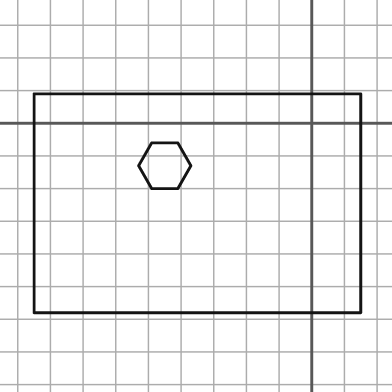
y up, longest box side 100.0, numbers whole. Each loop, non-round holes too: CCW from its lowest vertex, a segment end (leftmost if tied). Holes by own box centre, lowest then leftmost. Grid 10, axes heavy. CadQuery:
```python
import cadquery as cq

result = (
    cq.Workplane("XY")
    .moveTo(-85.0, -58.0)
    .lineTo(15.0, -58.0)
    .lineTo(15.0, 9.0)
    .lineTo(-85.0, 9.0)
    .close()
    .moveTo(-49.0, -20.0)
    .lineTo(-41.0, -20.0)
    .lineTo(-37.0, -13.0)
    .lineTo(-41.0, -6.0)
    .lineTo(-49.0, -6.0)
    .lineTo(-53.0, -13.0)
    .close()
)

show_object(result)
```